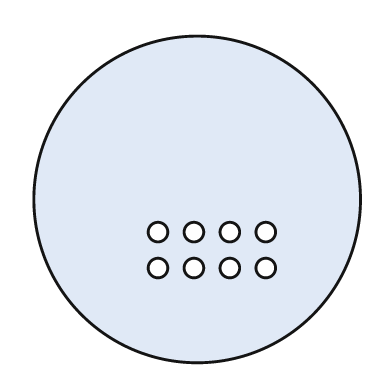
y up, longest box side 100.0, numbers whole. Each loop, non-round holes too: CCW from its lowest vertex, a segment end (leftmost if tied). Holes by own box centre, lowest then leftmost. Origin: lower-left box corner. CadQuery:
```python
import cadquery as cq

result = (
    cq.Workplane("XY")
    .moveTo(50.0, 50.0)
    .circle(50.0)
    .moveTo(38.0, 29.0)
    .circle(3.0)
    .moveTo(49.0, 29.0)
    .circle(3.0)
    .moveTo(60.0, 29.0)
    .circle(3.0)
    .moveTo(71.0, 29.0)
    .circle(3.0)
    .moveTo(38.0, 40.0)
    .circle(3.0)
    .moveTo(49.0, 40.0)
    .circle(3.0)
    .moveTo(60.0, 40.0)
    .circle(3.0)
    .moveTo(71.0, 40.0)
    .circle(3.0)
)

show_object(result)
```